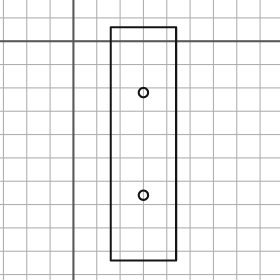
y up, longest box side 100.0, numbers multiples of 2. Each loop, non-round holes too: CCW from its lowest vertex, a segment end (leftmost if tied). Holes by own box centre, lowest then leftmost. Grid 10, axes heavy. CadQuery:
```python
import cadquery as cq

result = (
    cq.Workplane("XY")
    .moveTo(16.0, -94.0)
    .lineTo(44.0, -94.0)
    .lineTo(44.0, 6.0)
    .lineTo(16.0, 6.0)
    .close()
    .moveTo(30.0, -66.0)
    .circle(2.0)
    .moveTo(30.0, -22.0)
    .circle(2.0)
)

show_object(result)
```